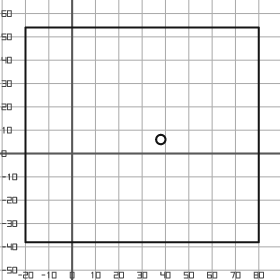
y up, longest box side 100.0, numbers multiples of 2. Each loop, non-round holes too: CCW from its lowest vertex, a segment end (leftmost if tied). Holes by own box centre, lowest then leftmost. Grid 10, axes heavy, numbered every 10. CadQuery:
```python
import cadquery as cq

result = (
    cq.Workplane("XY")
    .moveTo(-20.0, -38.0)
    .lineTo(80.0, -38.0)
    .lineTo(80.0, 54.0)
    .lineTo(-20.0, 54.0)
    .close()
    .moveTo(38.0, 6.0)
    .circle(2.0)
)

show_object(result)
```